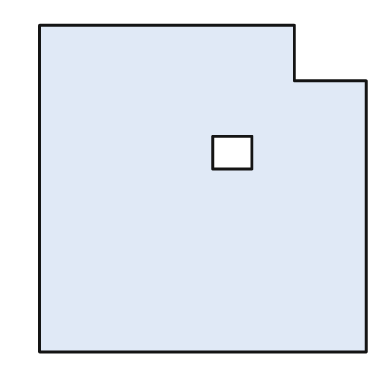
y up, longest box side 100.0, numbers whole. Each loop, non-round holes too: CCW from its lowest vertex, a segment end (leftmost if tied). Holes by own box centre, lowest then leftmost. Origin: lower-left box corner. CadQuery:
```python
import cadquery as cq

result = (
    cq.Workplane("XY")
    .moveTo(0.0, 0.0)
    .lineTo(100.0, 0.0)
    .lineTo(100.0, 83.0)
    .lineTo(78.0, 83.0)
    .lineTo(78.0, 100.0)
    .lineTo(0.0, 100.0)
    .close()
    .moveTo(53.0, 56.0)
    .lineTo(65.0, 56.0)
    .lineTo(65.0, 66.0)
    .lineTo(53.0, 66.0)
    .close()
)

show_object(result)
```